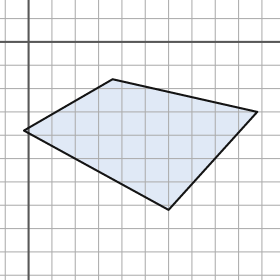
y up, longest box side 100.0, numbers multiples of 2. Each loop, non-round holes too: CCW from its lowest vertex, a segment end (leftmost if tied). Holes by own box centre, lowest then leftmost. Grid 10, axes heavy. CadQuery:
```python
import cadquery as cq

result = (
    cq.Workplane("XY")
    .moveTo(60.0, -72.0)
    .lineTo(98.0, -30.0)
    .lineTo(36.0, -16.0)
    .lineTo(-2.0, -38.0)
    .close()
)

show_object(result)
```